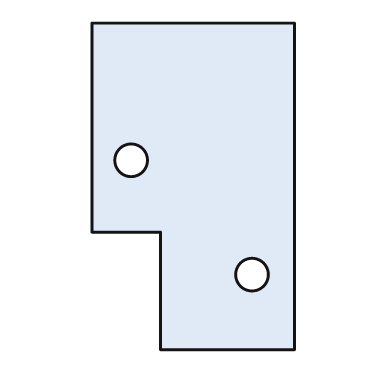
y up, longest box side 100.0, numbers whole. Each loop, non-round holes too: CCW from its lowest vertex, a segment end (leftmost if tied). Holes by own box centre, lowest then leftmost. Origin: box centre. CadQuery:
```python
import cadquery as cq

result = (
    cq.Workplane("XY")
    .moveTo(-10.0, -50.0)
    .lineTo(31.0, -50.0)
    .lineTo(31.0, 50.0)
    .lineTo(-31.0, 50.0)
    .lineTo(-31.0, -14.0)
    .lineTo(-10.0, -14.0)
    .close()
    .moveTo(18.0, -27.0)
    .circle(5.0)
    .moveTo(-19.0, 8.0)
    .circle(5.0)
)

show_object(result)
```